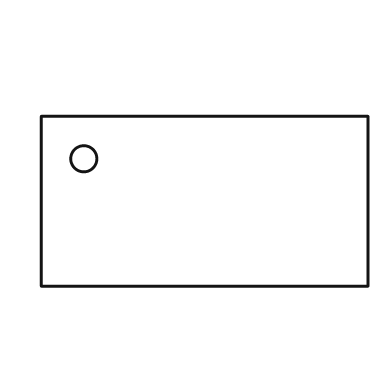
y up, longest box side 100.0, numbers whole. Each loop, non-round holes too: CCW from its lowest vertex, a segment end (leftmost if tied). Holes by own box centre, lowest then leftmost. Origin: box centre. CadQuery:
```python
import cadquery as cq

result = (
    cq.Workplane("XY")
    .moveTo(-50.0, -26.0)
    .lineTo(50.0, -26.0)
    .lineTo(50.0, 26.0)
    .lineTo(-50.0, 26.0)
    .close()
    .moveTo(-37.0, 13.0)
    .circle(4.0)
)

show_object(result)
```